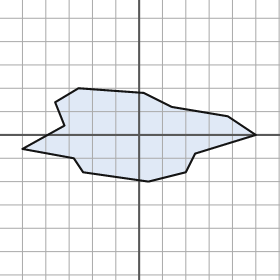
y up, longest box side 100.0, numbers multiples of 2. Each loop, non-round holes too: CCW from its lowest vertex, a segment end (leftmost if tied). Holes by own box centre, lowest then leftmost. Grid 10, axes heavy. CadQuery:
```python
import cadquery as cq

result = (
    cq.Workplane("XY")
    .moveTo(4.0, -20.0)
    .lineTo(20.0, -16.0)
    .lineTo(24.0, -8.0)
    .lineTo(50.0, 0.0)
    .lineTo(38.0, 8.0)
    .lineTo(14.0, 12.0)
    .lineTo(2.0, 18.0)
    .lineTo(-26.0, 20.0)
    .lineTo(-36.0, 14.0)
    .lineTo(-32.0, 4.0)
    .lineTo(-50.0, -6.0)
    .lineTo(-28.0, -10.0)
    .lineTo(-24.0, -16.0)
    .close()
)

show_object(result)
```